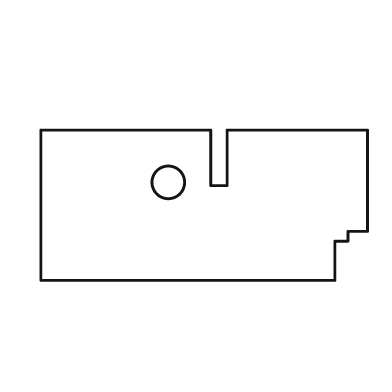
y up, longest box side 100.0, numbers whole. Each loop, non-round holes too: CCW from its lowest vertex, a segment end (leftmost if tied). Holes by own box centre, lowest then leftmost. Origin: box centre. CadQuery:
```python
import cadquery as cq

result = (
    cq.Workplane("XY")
    .moveTo(-50.0, -23.0)
    .lineTo(40.0, -23.0)
    .lineTo(40.0, -11.0)
    .lineTo(44.0, -11.0)
    .lineTo(44.0, -8.0)
    .lineTo(50.0, -8.0)
    .lineTo(50.0, 23.0)
    .lineTo(7.0, 23.0)
    .lineTo(7.0, 6.0)
    .lineTo(2.0, 6.0)
    .lineTo(2.0, 23.0)
    .lineTo(-50.0, 23.0)
    .close()
    .moveTo(-11.0, 7.0)
    .circle(5.0)
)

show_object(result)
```